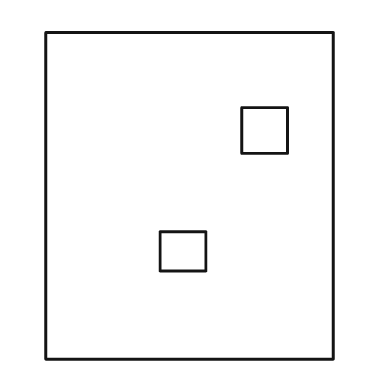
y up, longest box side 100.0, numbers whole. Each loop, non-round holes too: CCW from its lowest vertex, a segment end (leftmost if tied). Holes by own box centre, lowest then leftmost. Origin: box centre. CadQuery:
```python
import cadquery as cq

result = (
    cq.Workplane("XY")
    .moveTo(-44.0, -50.0)
    .lineTo(44.0, -50.0)
    .lineTo(44.0, 50.0)
    .lineTo(-44.0, 50.0)
    .close()
    .moveTo(-9.0, -23.0)
    .lineTo(5.0, -23.0)
    .lineTo(5.0, -11.0)
    .lineTo(-9.0, -11.0)
    .close()
    .moveTo(16.0, 13.0)
    .lineTo(30.0, 13.0)
    .lineTo(30.0, 27.0)
    .lineTo(16.0, 27.0)
    .close()
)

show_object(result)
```